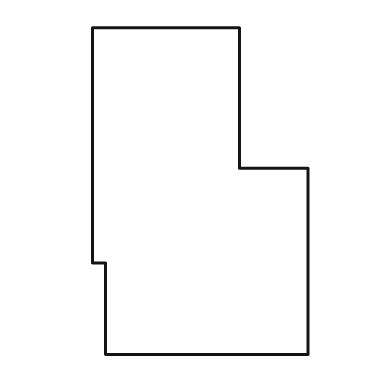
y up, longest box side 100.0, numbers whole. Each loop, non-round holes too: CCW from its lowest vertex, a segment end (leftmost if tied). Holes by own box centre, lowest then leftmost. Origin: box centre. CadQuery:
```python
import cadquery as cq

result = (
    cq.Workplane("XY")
    .moveTo(-29.0, -50.0)
    .lineTo(33.0, -50.0)
    .lineTo(33.0, 7.0)
    .lineTo(12.0, 7.0)
    .lineTo(12.0, 50.0)
    .lineTo(-33.0, 50.0)
    .lineTo(-33.0, -22.0)
    .lineTo(-29.0, -22.0)
    .close()
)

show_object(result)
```